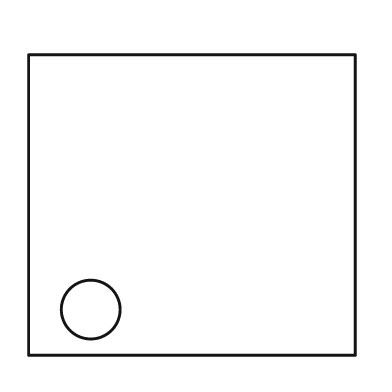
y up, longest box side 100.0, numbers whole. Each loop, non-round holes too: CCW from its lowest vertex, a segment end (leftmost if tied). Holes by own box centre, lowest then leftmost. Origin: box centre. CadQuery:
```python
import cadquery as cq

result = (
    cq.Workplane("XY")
    .moveTo(-50.0, -46.0)
    .lineTo(50.0, -46.0)
    .lineTo(50.0, 46.0)
    .lineTo(-50.0, 46.0)
    .close()
    .moveTo(-31.0, -32.0)
    .circle(9.0)
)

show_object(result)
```